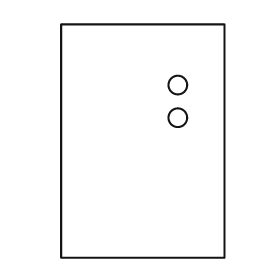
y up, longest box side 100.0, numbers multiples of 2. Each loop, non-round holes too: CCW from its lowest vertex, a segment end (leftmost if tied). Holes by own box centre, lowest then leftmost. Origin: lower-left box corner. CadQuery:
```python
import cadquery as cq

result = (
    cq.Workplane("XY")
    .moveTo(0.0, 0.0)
    .lineTo(70.0, 0.0)
    .lineTo(70.0, 100.0)
    .lineTo(0.0, 100.0)
    .close()
    .moveTo(50.0, 60.0)
    .circle(4.0)
    .moveTo(50.0, 74.0)
    .circle(4.0)
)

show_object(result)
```